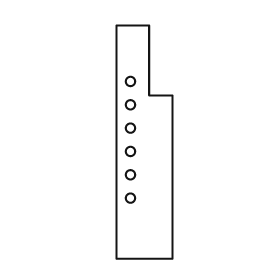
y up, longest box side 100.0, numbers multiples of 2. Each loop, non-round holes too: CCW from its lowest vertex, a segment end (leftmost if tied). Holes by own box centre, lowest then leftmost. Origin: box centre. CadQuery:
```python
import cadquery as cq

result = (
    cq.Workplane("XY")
    .moveTo(-12.0, -50.0)
    .lineTo(12.0, -50.0)
    .lineTo(12.0, 20.0)
    .lineTo(2.0, 20.0)
    .lineTo(2.0, 50.0)
    .lineTo(-12.0, 50.0)
    .close()
    .moveTo(-6.0, -24.0)
    .circle(2.0)
    .moveTo(-6.0, -14.0)
    .circle(2.0)
    .moveTo(-6.0, -4.0)
    .circle(2.0)
    .moveTo(-6.0, 6.0)
    .circle(2.0)
    .moveTo(-6.0, 16.0)
    .circle(2.0)
    .moveTo(-6.0, 26.0)
    .circle(2.0)
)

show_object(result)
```